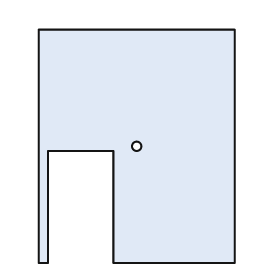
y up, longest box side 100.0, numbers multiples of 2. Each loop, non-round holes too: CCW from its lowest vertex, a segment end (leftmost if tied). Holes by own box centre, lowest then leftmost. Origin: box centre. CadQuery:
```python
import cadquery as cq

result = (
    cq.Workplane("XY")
    .moveTo(-42.0, -50.0)
    .lineTo(-38.0, -50.0)
    .lineTo(-38.0, -2.0)
    .lineTo(-10.0, -2.0)
    .lineTo(-10.0, -50.0)
    .lineTo(42.0, -50.0)
    .lineTo(42.0, 50.0)
    .lineTo(-42.0, 50.0)
    .close()
    .moveTo(0.0, 0.0)
    .circle(2.0)
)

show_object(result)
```